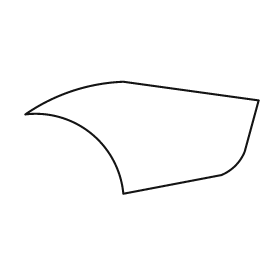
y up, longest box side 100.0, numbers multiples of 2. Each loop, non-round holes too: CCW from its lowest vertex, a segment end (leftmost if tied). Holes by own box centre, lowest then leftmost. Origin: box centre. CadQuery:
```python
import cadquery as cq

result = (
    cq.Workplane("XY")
    .moveTo(-8.0, -24.0)
    .lineTo(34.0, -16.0)
    .threePointArc((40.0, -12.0), (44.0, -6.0))
    .lineTo(50.0, 16.0)
    .lineTo(-8.0, 24.0)
    .threePointArc((-30.0, 20.0), (-50.0, 10.0))
    .threePointArc((-22.0, 2.0), (-8.0, -24.0))
    .close()
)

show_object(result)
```